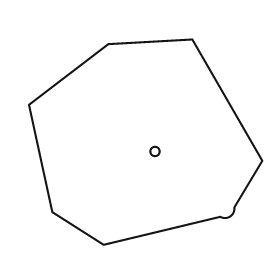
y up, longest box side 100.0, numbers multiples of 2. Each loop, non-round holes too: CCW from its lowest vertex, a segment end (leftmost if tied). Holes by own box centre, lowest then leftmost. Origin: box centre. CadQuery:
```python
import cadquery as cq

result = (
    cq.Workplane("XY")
    .moveTo(-18.0, -44.0)
    .lineTo(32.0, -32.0)
    .threePointArc((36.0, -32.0), (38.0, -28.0))
    .lineTo(50.0, -8.0)
    .lineTo(20.0, 44.0)
    .lineTo(-16.0, 42.0)
    .lineTo(-50.0, 16.0)
    .lineTo(-40.0, -30.0)
    .close()
    .moveTo(4.0, -4.0)
    .circle(2.0)
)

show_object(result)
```